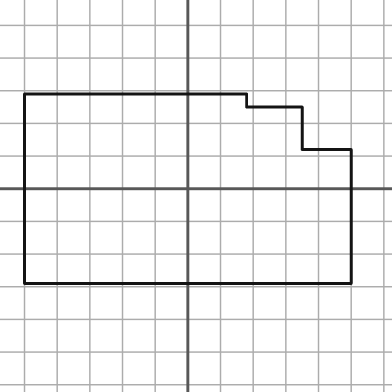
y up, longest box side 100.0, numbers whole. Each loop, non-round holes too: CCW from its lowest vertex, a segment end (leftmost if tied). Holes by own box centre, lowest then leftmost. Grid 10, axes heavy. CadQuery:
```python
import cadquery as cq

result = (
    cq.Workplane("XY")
    .moveTo(-50.0, -29.0)
    .lineTo(50.0, -29.0)
    .lineTo(50.0, 12.0)
    .lineTo(35.0, 12.0)
    .lineTo(35.0, 25.0)
    .lineTo(18.0, 25.0)
    .lineTo(18.0, 29.0)
    .lineTo(-50.0, 29.0)
    .close()
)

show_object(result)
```